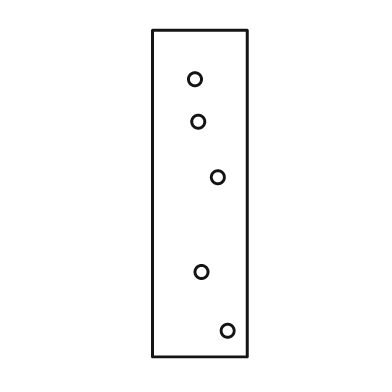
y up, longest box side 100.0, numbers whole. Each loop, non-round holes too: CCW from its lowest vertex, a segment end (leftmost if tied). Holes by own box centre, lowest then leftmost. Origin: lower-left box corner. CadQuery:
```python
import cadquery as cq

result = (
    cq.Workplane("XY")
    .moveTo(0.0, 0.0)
    .lineTo(29.0, 0.0)
    .lineTo(29.0, 100.0)
    .lineTo(0.0, 100.0)
    .close()
    .moveTo(23.0, 8.0)
    .circle(2.0)
    .moveTo(15.0, 26.0)
    .circle(2.0)
    .moveTo(20.0, 55.0)
    .circle(2.0)
    .moveTo(14.0, 72.0)
    .circle(2.0)
    .moveTo(13.0, 85.0)
    .circle(2.0)
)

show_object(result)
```